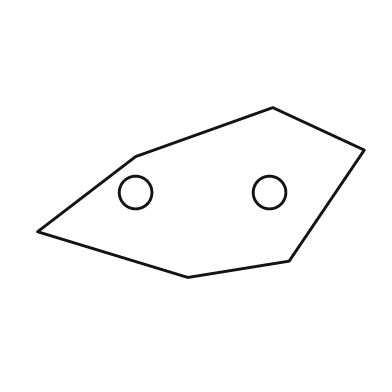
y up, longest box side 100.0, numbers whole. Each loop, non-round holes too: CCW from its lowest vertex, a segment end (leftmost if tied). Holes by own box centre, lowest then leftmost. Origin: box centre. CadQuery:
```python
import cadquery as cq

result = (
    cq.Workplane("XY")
    .moveTo(-4.0, -26.0)
    .lineTo(27.0, -21.0)
    .lineTo(50.0, 13.0)
    .lineTo(22.0, 26.0)
    .lineTo(-20.0, 11.0)
    .lineTo(-50.0, -12.0)
    .close()
    .moveTo(-20.0, 0.0)
    .circle(5.0)
    .moveTo(21.0, 0.0)
    .circle(5.0)
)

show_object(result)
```